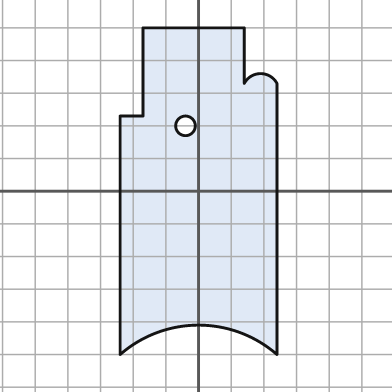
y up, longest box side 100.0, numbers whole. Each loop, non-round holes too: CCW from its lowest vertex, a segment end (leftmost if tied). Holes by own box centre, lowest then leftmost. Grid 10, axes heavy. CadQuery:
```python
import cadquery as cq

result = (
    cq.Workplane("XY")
    .moveTo(-24.0, -50.0)
    .threePointArc((0.0, -41.0), (24.0, -50.0))
    .lineTo(24.0, 33.0)
    .threePointArc((19.0, 36.0), (14.0, 33.0))
    .lineTo(14.0, 50.0)
    .lineTo(-17.0, 50.0)
    .lineTo(-17.0, 23.0)
    .lineTo(-24.0, 23.0)
    .close()
    .moveTo(-4.0, 20.0)
    .circle(3.0)
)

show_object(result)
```